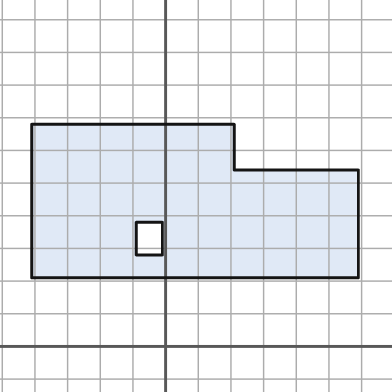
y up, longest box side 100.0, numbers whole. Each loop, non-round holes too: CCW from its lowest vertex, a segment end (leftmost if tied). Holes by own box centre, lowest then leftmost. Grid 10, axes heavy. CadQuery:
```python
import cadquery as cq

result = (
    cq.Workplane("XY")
    .moveTo(-41.0, 21.0)
    .lineTo(59.0, 21.0)
    .lineTo(59.0, 54.0)
    .lineTo(21.0, 54.0)
    .lineTo(21.0, 68.0)
    .lineTo(-41.0, 68.0)
    .close()
    .moveTo(-9.0, 28.0)
    .lineTo(-1.0, 28.0)
    .lineTo(-1.0, 38.0)
    .lineTo(-9.0, 38.0)
    .close()
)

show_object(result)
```